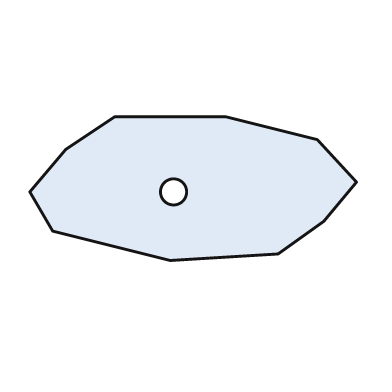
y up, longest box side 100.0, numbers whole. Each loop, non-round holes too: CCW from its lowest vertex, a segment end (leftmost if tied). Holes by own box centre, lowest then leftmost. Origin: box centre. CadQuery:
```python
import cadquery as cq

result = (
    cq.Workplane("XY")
    .moveTo(-7.0, -22.0)
    .lineTo(26.0, -20.0)
    .lineTo(40.0, -10.0)
    .lineTo(50.0, 2.0)
    .lineTo(38.0, 15.0)
    .lineTo(10.0, 22.0)
    .lineTo(-24.0, 22.0)
    .lineTo(-39.0, 12.0)
    .lineTo(-50.0, -1.0)
    .lineTo(-43.0, -13.0)
    .close()
    .moveTo(-6.0, -1.0)
    .circle(4.0)
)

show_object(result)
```